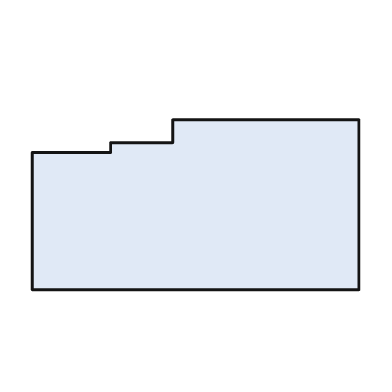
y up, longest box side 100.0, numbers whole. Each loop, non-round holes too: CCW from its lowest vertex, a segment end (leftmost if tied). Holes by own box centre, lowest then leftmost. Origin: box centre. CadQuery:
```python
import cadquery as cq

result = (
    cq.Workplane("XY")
    .moveTo(-50.0, -26.0)
    .lineTo(50.0, -26.0)
    .lineTo(50.0, 26.0)
    .lineTo(-7.0, 26.0)
    .lineTo(-7.0, 19.0)
    .lineTo(-26.0, 19.0)
    .lineTo(-26.0, 16.0)
    .lineTo(-50.0, 16.0)
    .close()
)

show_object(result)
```